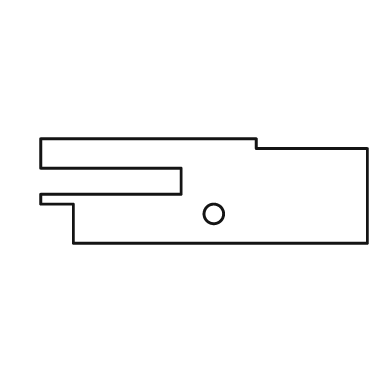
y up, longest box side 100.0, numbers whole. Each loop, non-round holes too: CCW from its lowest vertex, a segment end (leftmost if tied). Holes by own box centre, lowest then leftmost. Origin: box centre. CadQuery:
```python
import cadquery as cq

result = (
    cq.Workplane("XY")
    .moveTo(-40.0, -16.0)
    .lineTo(50.0, -16.0)
    .lineTo(50.0, 13.0)
    .lineTo(16.0, 13.0)
    .lineTo(16.0, 16.0)
    .lineTo(-50.0, 16.0)
    .lineTo(-50.0, 7.0)
    .lineTo(-7.0, 7.0)
    .lineTo(-7.0, -1.0)
    .lineTo(-50.0, -1.0)
    .lineTo(-50.0, -4.0)
    .lineTo(-40.0, -4.0)
    .close()
    .moveTo(3.0, -7.0)
    .circle(3.0)
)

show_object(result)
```